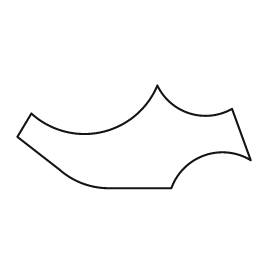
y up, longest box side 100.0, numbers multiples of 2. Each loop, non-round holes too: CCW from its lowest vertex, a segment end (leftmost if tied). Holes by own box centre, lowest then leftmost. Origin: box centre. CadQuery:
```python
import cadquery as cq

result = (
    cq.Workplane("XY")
    .moveTo(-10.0, -22.0)
    .lineTo(16.0, -22.0)
    .threePointArc((30.0, -8.0), (50.0, -10.0))
    .lineTo(42.0, 12.0)
    .threePointArc((24.0, 10.0), (10.0, 22.0))
    .threePointArc((-14.0, 2.0), (-44.0, 10.0))
    .lineTo(-50.0, 0.0)
    .lineTo(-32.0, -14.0)
    .threePointArc((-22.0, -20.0), (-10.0, -22.0))
    .close()
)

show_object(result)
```